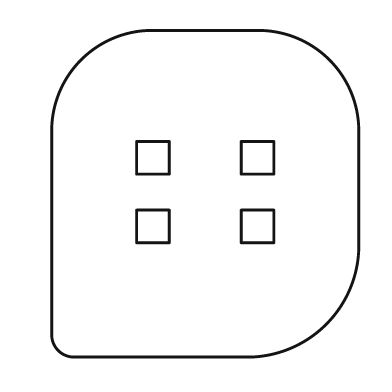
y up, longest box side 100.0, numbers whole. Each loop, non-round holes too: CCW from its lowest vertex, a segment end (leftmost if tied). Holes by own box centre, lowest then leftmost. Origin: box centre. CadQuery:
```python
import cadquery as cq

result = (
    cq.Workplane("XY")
    .moveTo(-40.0, -50.0)
    .lineTo(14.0, -50.0)
    .threePointArc((37.0, -40.0), (47.0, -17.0))
    .lineTo(47.0, 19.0)
    .threePointArc((38.0, 41.0), (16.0, 50.0))
    .lineTo(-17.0, 50.0)
    .threePointArc((-38.0, 41.0), (-47.0, 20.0))
    .lineTo(-47.0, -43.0)
    .threePointArc((-45.0, -48.0), (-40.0, -50.0))
    .close()
    .moveTo(-21.0, -15.0)
    .lineTo(-11.0, -15.0)
    .lineTo(-11.0, -5.0)
    .lineTo(-21.0, -5.0)
    .close()
    .moveTo(11.0, -15.0)
    .lineTo(21.0, -15.0)
    .lineTo(21.0, -5.0)
    .lineTo(11.0, -5.0)
    .close()
    .moveTo(-21.0, 6.0)
    .lineTo(-11.0, 6.0)
    .lineTo(-11.0, 16.0)
    .lineTo(-21.0, 16.0)
    .close()
    .moveTo(11.0, 6.0)
    .lineTo(21.0, 6.0)
    .lineTo(21.0, 16.0)
    .lineTo(11.0, 16.0)
    .close()
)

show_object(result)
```